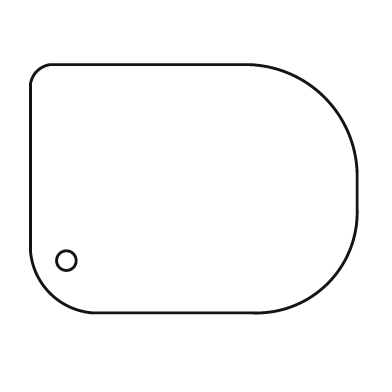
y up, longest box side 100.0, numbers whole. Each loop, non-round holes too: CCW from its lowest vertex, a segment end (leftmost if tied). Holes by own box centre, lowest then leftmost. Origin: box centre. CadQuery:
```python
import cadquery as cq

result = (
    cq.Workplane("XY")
    .moveTo(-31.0, -38.0)
    .lineTo(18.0, -38.0)
    .threePointArc((41.0, -29.0), (50.0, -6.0))
    .lineTo(50.0, 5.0)
    .threePointArc((40.0, 28.0), (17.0, 38.0))
    .lineTo(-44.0, 38.0)
    .threePointArc((-48.0, 36.0), (-50.0, 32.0))
    .lineTo(-50.0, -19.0)
    .threePointArc((-44.0, -32.0), (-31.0, -38.0))
    .close()
    .moveTo(-39.0, -22.0)
    .circle(3.0)
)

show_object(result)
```